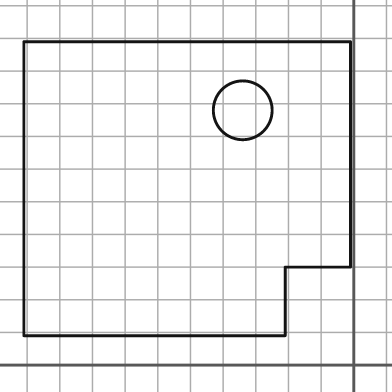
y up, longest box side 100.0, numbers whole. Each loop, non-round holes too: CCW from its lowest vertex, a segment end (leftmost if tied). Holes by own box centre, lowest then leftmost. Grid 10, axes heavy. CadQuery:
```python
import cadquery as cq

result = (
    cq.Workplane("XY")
    .moveTo(-101.0, 9.0)
    .lineTo(-21.0, 9.0)
    .lineTo(-21.0, 30.0)
    .lineTo(-1.0, 30.0)
    .lineTo(-1.0, 99.0)
    .lineTo(-101.0, 99.0)
    .close()
    .moveTo(-34.0, 78.0)
    .circle(9.0)
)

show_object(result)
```